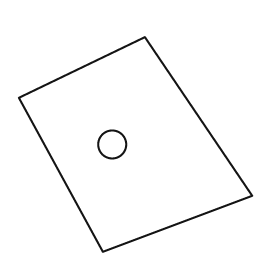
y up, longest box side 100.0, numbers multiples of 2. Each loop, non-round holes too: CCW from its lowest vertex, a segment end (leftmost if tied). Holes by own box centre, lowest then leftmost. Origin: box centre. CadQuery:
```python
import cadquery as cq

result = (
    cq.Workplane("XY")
    .moveTo(-14.0, -46.0)
    .lineTo(50.0, -22.0)
    .lineTo(4.0, 46.0)
    .lineTo(-50.0, 20.0)
    .close()
    .moveTo(-10.0, 0.0)
    .circle(6.0)
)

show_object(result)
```